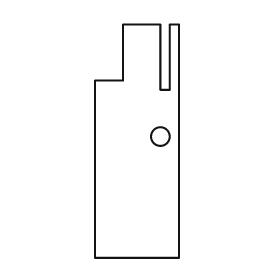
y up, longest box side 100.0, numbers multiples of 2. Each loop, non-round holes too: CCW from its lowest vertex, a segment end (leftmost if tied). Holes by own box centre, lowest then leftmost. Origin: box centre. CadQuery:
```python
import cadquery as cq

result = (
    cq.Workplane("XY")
    .moveTo(-18.0, -50.0)
    .lineTo(18.0, -50.0)
    .lineTo(18.0, 50.0)
    .lineTo(14.0, 50.0)
    .lineTo(14.0, 22.0)
    .lineTo(10.0, 22.0)
    .lineTo(10.0, 50.0)
    .lineTo(-6.0, 50.0)
    .lineTo(-6.0, 26.0)
    .lineTo(-18.0, 26.0)
    .close()
    .moveTo(10.0, 2.0)
    .circle(4.0)
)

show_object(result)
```